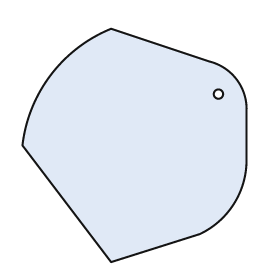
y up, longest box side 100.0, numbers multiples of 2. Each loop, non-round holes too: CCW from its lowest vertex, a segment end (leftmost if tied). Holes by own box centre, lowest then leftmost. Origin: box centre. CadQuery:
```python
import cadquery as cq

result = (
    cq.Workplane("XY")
    .moveTo(-10.0, -50.0)
    .lineTo(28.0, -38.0)
    .threePointArc((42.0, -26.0), (48.0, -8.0))
    .lineTo(48.0, 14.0)
    .threePointArc((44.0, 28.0), (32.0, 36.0))
    .lineTo(-10.0, 50.0)
    .threePointArc((-36.0, 30.0), (-48.0, 0.0))
    .close()
    .moveTo(36.0, 22.0)
    .circle(2.0)
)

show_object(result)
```